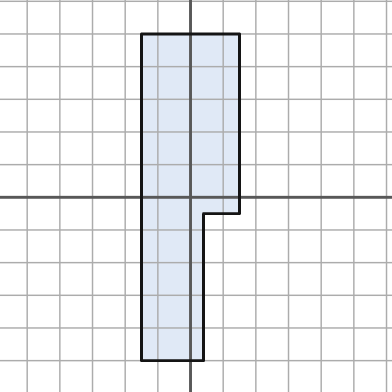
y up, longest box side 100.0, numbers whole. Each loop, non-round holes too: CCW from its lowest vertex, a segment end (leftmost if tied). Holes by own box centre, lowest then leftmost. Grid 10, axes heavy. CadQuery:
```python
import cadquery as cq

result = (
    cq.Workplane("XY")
    .moveTo(-15.0, -50.0)
    .lineTo(4.0, -50.0)
    .lineTo(4.0, -5.0)
    .lineTo(15.0, -5.0)
    .lineTo(15.0, 50.0)
    .lineTo(-15.0, 50.0)
    .close()
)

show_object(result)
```